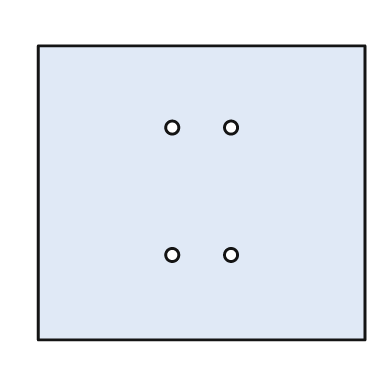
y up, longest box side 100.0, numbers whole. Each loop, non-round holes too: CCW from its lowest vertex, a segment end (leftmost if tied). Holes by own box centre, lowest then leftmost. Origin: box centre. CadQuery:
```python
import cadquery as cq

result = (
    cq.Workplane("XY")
    .moveTo(-50.0, -45.0)
    .lineTo(50.0, -45.0)
    .lineTo(50.0, 45.0)
    .lineTo(-50.0, 45.0)
    .close()
    .moveTo(-9.0, -19.0)
    .circle(2.0)
    .moveTo(9.0, -19.0)
    .circle(2.0)
    .moveTo(-9.0, 20.0)
    .circle(2.0)
    .moveTo(9.0, 20.0)
    .circle(2.0)
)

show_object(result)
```